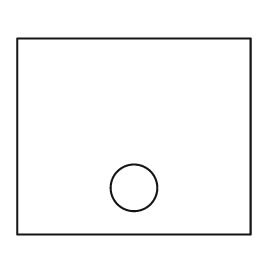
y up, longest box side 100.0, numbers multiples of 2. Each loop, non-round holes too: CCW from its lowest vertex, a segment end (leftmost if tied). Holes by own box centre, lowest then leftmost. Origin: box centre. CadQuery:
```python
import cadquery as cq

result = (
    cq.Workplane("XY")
    .moveTo(-50.0, -42.0)
    .lineTo(50.0, -42.0)
    .lineTo(50.0, 42.0)
    .lineTo(-50.0, 42.0)
    .close()
    .moveTo(0.0, -22.0)
    .circle(10.0)
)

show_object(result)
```